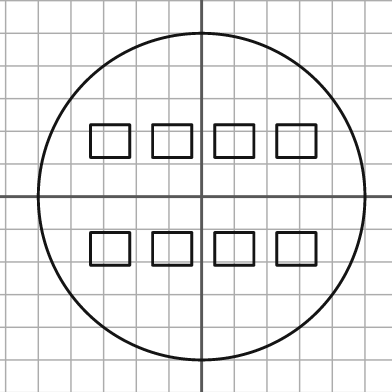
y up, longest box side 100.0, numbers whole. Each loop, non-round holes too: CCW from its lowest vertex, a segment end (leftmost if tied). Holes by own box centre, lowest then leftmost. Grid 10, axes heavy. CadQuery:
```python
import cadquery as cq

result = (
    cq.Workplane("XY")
    .moveTo(0.0, 0.0)
    .circle(50.0)
    .moveTo(-34.0, -21.0)
    .lineTo(-22.0, -21.0)
    .lineTo(-22.0, -11.0)
    .lineTo(-34.0, -11.0)
    .close()
    .moveTo(-15.0, -21.0)
    .lineTo(-3.0, -21.0)
    .lineTo(-3.0, -11.0)
    .lineTo(-15.0, -11.0)
    .close()
    .moveTo(4.0, -21.0)
    .lineTo(16.0, -21.0)
    .lineTo(16.0, -11.0)
    .lineTo(4.0, -11.0)
    .close()
    .moveTo(23.0, -21.0)
    .lineTo(35.0, -21.0)
    .lineTo(35.0, -11.0)
    .lineTo(23.0, -11.0)
    .close()
    .moveTo(-34.0, 12.0)
    .lineTo(-22.0, 12.0)
    .lineTo(-22.0, 22.0)
    .lineTo(-34.0, 22.0)
    .close()
    .moveTo(-15.0, 12.0)
    .lineTo(-3.0, 12.0)
    .lineTo(-3.0, 22.0)
    .lineTo(-15.0, 22.0)
    .close()
    .moveTo(4.0, 12.0)
    .lineTo(16.0, 12.0)
    .lineTo(16.0, 22.0)
    .lineTo(4.0, 22.0)
    .close()
    .moveTo(23.0, 12.0)
    .lineTo(35.0, 12.0)
    .lineTo(35.0, 22.0)
    .lineTo(23.0, 22.0)
    .close()
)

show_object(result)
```